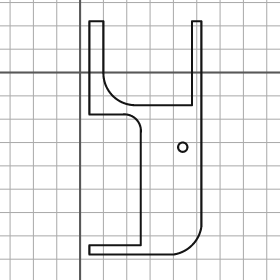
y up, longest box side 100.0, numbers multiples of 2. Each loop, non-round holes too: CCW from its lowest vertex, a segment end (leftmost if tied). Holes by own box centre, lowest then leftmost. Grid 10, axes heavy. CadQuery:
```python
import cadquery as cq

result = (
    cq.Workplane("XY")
    .moveTo(4.0, -78.0)
    .lineTo(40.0, -78.0)
    .threePointArc((48.0, -74.0), (52.0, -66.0))
    .lineTo(52.0, 22.0)
    .lineTo(48.0, 22.0)
    .lineTo(48.0, -14.0)
    .lineTo(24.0, -14.0)
    .threePointArc((14.0, -10.0), (10.0, 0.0))
    .lineTo(10.0, 22.0)
    .lineTo(4.0, 22.0)
    .lineTo(4.0, -18.0)
    .lineTo(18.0, -18.0)
    .threePointArc((24.0, -20.0), (26.0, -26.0))
    .lineTo(26.0, -74.0)
    .lineTo(4.0, -74.0)
    .close()
    .moveTo(44.0, -32.0)
    .circle(2.0)
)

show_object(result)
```